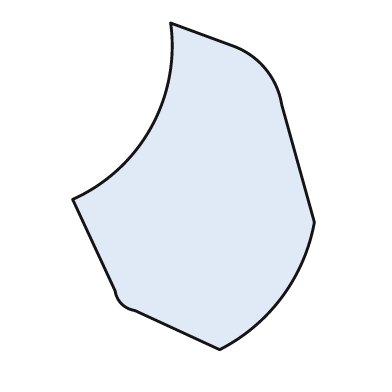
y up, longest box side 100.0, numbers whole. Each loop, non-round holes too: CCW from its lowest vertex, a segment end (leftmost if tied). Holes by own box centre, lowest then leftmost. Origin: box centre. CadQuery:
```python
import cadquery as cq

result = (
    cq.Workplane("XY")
    .moveTo(8.0, -50.0)
    .threePointArc((27.0, -34.0), (37.0, -11.0))
    .lineTo(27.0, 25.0)
    .threePointArc((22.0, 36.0), (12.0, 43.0))
    .lineTo(-7.0, 50.0)
    .threePointArc((-13.0, 18.0), (-37.0, -4.0))
    .lineTo(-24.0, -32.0)
    .threePointArc((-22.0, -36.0), (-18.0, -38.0))
    .close()
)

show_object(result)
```